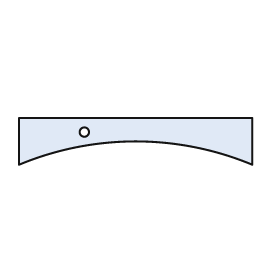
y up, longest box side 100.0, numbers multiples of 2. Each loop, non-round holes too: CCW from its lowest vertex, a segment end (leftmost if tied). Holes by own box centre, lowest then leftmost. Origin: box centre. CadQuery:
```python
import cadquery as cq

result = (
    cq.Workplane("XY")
    .moveTo(-50.0, -10.0)
    .threePointArc((0.0, 0.0), (50.0, -10.0))
    .lineTo(50.0, 10.0)
    .lineTo(-50.0, 10.0)
    .close()
    .moveTo(-22.0, 4.0)
    .circle(2.0)
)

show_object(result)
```